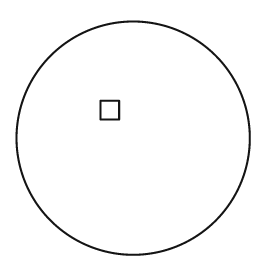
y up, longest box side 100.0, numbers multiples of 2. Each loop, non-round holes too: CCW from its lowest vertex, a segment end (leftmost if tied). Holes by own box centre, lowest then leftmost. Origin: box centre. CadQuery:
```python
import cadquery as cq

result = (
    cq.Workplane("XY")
    .moveTo(0.0, 0.0)
    .circle(50.0)
    .moveTo(-14.0, 8.0)
    .lineTo(-6.0, 8.0)
    .lineTo(-6.0, 16.0)
    .lineTo(-14.0, 16.0)
    .close()
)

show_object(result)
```